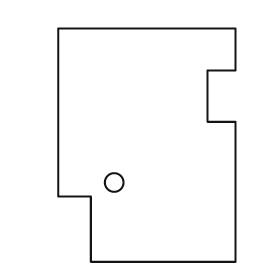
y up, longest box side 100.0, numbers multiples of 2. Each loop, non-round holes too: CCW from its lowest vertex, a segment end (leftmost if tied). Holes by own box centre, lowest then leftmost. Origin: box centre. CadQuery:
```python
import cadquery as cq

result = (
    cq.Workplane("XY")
    .moveTo(-24.0, -50.0)
    .lineTo(38.0, -50.0)
    .lineTo(38.0, 10.0)
    .lineTo(26.0, 10.0)
    .lineTo(26.0, 32.0)
    .lineTo(38.0, 32.0)
    .lineTo(38.0, 50.0)
    .lineTo(-38.0, 50.0)
    .lineTo(-38.0, -22.0)
    .lineTo(-24.0, -22.0)
    .close()
    .moveTo(-14.0, -16.0)
    .circle(4.0)
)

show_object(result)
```